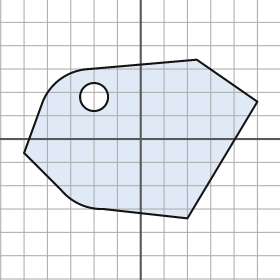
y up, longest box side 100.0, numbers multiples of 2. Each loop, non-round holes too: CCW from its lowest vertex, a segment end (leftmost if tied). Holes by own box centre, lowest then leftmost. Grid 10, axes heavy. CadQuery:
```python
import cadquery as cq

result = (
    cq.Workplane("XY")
    .moveTo(20.0, -34.0)
    .lineTo(50.0, 16.0)
    .lineTo(24.0, 34.0)
    .lineTo(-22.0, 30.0)
    .threePointArc((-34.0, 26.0), (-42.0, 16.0))
    .lineTo(-50.0, -6.0)
    .lineTo(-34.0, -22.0)
    .threePointArc((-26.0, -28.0), (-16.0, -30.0))
    .close()
    .moveTo(-20.0, 18.0)
    .circle(6.0)
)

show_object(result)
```